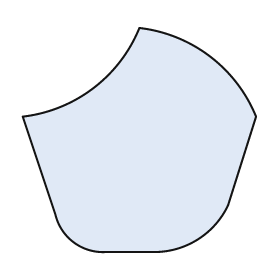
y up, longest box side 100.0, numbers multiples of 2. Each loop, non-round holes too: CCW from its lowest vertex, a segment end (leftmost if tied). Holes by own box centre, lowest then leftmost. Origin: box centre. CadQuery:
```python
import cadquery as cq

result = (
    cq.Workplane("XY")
    .moveTo(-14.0, -48.0)
    .lineTo(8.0, -48.0)
    .threePointArc((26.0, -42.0), (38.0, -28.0))
    .lineTo(50.0, 10.0)
    .threePointArc((30.0, 36.0), (0.0, 48.0))
    .threePointArc((-20.0, 22.0), (-50.0, 10.0))
    .lineTo(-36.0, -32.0)
    .threePointArc((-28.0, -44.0), (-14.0, -48.0))
    .close()
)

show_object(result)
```